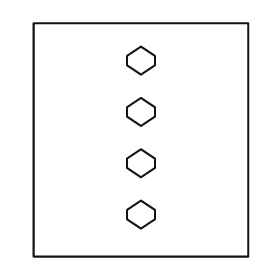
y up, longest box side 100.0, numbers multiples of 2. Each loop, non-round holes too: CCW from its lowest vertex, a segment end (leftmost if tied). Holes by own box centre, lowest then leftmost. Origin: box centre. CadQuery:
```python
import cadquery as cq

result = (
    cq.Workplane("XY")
    .moveTo(-46.0, -50.0)
    .lineTo(46.0, -50.0)
    .lineTo(46.0, 50.0)
    .lineTo(-46.0, 50.0)
    .close()
    .moveTo(0.0, -38.0)
    .lineTo(6.0, -34.0)
    .lineTo(6.0, -30.0)
    .lineTo(0.0, -26.0)
    .lineTo(-6.0, -30.0)
    .lineTo(-6.0, -34.0)
    .close()
    .moveTo(0.0, -16.0)
    .lineTo(6.0, -12.0)
    .lineTo(6.0, -8.0)
    .lineTo(0.0, -4.0)
    .lineTo(-6.0, -8.0)
    .lineTo(-6.0, -12.0)
    .close()
    .moveTo(0.0, 6.0)
    .lineTo(6.0, 10.0)
    .lineTo(6.0, 14.0)
    .lineTo(0.0, 18.0)
    .lineTo(-6.0, 14.0)
    .lineTo(-6.0, 10.0)
    .close()
    .moveTo(0.0, 28.0)
    .lineTo(6.0, 32.0)
    .lineTo(6.0, 36.0)
    .lineTo(0.0, 40.0)
    .lineTo(-6.0, 36.0)
    .lineTo(-6.0, 32.0)
    .close()
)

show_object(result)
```